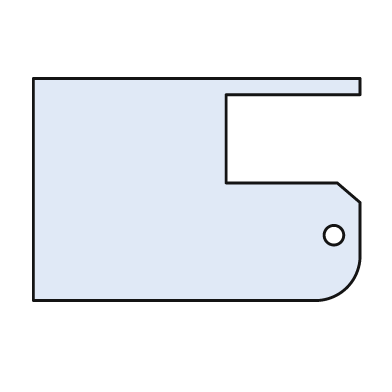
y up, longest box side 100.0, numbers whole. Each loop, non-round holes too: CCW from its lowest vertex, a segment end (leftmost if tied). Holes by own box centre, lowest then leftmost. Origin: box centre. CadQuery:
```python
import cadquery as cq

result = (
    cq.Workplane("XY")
    .moveTo(-50.0, -34.0)
    .lineTo(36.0, -34.0)
    .threePointArc((46.0, -30.0), (50.0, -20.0))
    .lineTo(50.0, -4.0)
    .lineTo(43.0, 2.0)
    .lineTo(9.0, 2.0)
    .lineTo(9.0, 29.0)
    .lineTo(50.0, 29.0)
    .lineTo(50.0, 34.0)
    .lineTo(-50.0, 34.0)
    .close()
    .moveTo(42.0, -14.0)
    .circle(3.0)
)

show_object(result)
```